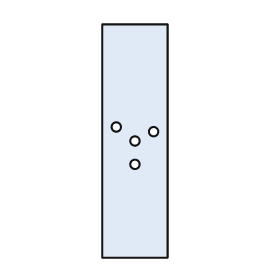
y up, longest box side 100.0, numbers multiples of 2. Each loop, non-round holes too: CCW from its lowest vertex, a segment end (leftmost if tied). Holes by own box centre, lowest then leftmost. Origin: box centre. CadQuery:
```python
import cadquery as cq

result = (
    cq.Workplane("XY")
    .moveTo(-14.0, -50.0)
    .lineTo(14.0, -50.0)
    .lineTo(14.0, 50.0)
    .lineTo(-14.0, 50.0)
    .close()
    .moveTo(0.0, -10.0)
    .circle(2.0)
    .moveTo(0.0, 0.0)
    .circle(2.0)
    .moveTo(8.0, 4.0)
    .circle(2.0)
    .moveTo(-8.0, 6.0)
    .circle(2.0)
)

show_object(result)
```